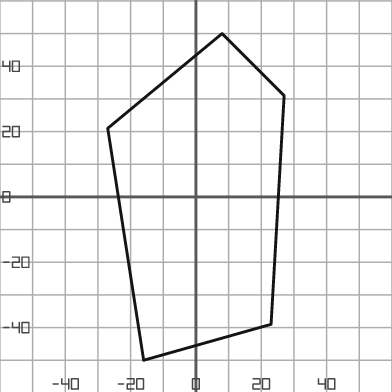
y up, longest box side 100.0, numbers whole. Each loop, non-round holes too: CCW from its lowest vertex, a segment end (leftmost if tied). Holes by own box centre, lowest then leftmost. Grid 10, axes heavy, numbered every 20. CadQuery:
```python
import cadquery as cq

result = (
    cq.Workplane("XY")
    .moveTo(-16.0, -50.0)
    .lineTo(23.0, -39.0)
    .lineTo(27.0, 31.0)
    .lineTo(8.0, 50.0)
    .lineTo(-27.0, 21.0)
    .close()
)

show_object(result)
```